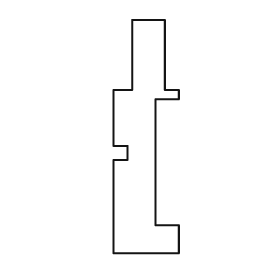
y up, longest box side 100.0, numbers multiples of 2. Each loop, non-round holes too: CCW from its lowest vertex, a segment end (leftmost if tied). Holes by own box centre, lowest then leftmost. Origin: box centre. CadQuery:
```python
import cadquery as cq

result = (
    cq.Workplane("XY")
    .moveTo(-14.0, -50.0)
    .lineTo(14.0, -50.0)
    .lineTo(14.0, -38.0)
    .lineTo(4.0, -38.0)
    .lineTo(4.0, 16.0)
    .lineTo(14.0, 16.0)
    .lineTo(14.0, 20.0)
    .lineTo(8.0, 20.0)
    .lineTo(8.0, 50.0)
    .lineTo(-6.0, 50.0)
    .lineTo(-6.0, 20.0)
    .lineTo(-14.0, 20.0)
    .lineTo(-14.0, -4.0)
    .lineTo(-8.0, -4.0)
    .lineTo(-8.0, -10.0)
    .lineTo(-14.0, -10.0)
    .close()
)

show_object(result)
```